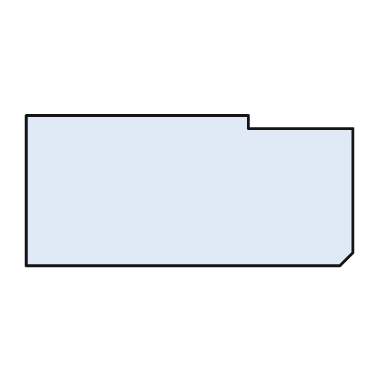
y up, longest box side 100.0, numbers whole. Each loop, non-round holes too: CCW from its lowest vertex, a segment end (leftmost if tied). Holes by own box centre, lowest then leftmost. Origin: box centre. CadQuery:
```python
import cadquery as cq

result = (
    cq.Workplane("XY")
    .moveTo(-50.0, -23.0)
    .lineTo(46.0, -23.0)
    .lineTo(50.0, -19.0)
    .lineTo(50.0, 19.0)
    .lineTo(18.0, 19.0)
    .lineTo(18.0, 23.0)
    .lineTo(-50.0, 23.0)
    .close()
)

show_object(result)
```